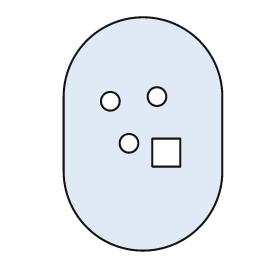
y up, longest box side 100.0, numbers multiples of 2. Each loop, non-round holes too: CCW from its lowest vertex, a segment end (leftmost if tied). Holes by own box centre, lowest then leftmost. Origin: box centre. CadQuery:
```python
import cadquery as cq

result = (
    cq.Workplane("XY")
    .moveTo(-34.0, -16.0)
    .threePointArc((0.0, -50.0), (34.0, -16.0))
    .lineTo(34.0, 16.0)
    .threePointArc((0.0, 50.0), (-34.0, 16.0))
    .close()
    .moveTo(4.0, -14.0)
    .lineTo(16.0, -14.0)
    .lineTo(16.0, -2.0)
    .lineTo(4.0, -2.0)
    .close()
    .moveTo(-6.0, -4.0)
    .circle(4.0)
    .moveTo(-14.0, 14.0)
    .circle(4.0)
    .moveTo(6.0, 16.0)
    .circle(4.0)
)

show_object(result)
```